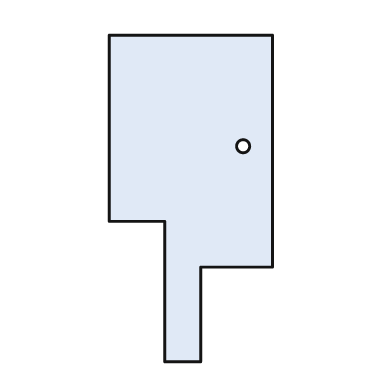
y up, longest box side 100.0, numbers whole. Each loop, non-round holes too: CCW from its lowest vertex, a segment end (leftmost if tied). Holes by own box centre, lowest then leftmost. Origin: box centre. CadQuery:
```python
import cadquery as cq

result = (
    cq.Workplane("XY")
    .moveTo(-8.0, -50.0)
    .lineTo(3.0, -50.0)
    .lineTo(3.0, -21.0)
    .lineTo(25.0, -21.0)
    .lineTo(25.0, 50.0)
    .lineTo(-25.0, 50.0)
    .lineTo(-25.0, -7.0)
    .lineTo(-8.0, -7.0)
    .close()
    .moveTo(16.0, 16.0)
    .circle(2.0)
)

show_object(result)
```